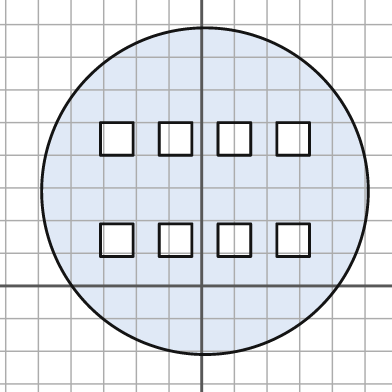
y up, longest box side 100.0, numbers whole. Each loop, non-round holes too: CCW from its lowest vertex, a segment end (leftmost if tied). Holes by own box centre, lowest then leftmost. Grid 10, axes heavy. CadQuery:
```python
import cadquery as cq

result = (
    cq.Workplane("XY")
    .moveTo(1.0, 29.0)
    .circle(50.0)
    .moveTo(-31.0, 9.0)
    .lineTo(-21.0, 9.0)
    .lineTo(-21.0, 19.0)
    .lineTo(-31.0, 19.0)
    .close()
    .moveTo(-13.0, 9.0)
    .lineTo(-3.0, 9.0)
    .lineTo(-3.0, 19.0)
    .lineTo(-13.0, 19.0)
    .close()
    .moveTo(5.0, 9.0)
    .lineTo(15.0, 9.0)
    .lineTo(15.0, 19.0)
    .lineTo(5.0, 19.0)
    .close()
    .moveTo(23.0, 9.0)
    .lineTo(33.0, 9.0)
    .lineTo(33.0, 19.0)
    .lineTo(23.0, 19.0)
    .close()
    .moveTo(-31.0, 40.0)
    .lineTo(-21.0, 40.0)
    .lineTo(-21.0, 50.0)
    .lineTo(-31.0, 50.0)
    .close()
    .moveTo(-13.0, 40.0)
    .lineTo(-3.0, 40.0)
    .lineTo(-3.0, 50.0)
    .lineTo(-13.0, 50.0)
    .close()
    .moveTo(5.0, 40.0)
    .lineTo(15.0, 40.0)
    .lineTo(15.0, 50.0)
    .lineTo(5.0, 50.0)
    .close()
    .moveTo(23.0, 40.0)
    .lineTo(33.0, 40.0)
    .lineTo(33.0, 50.0)
    .lineTo(23.0, 50.0)
    .close()
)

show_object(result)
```